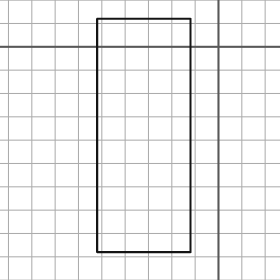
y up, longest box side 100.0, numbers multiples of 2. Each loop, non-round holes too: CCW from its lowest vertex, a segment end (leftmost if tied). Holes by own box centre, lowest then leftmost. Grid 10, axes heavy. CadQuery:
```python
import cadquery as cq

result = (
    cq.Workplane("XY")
    .moveTo(-52.0, -88.0)
    .lineTo(-12.0, -88.0)
    .lineTo(-12.0, 12.0)
    .lineTo(-52.0, 12.0)
    .close()
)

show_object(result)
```